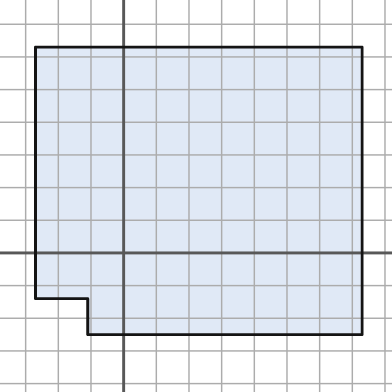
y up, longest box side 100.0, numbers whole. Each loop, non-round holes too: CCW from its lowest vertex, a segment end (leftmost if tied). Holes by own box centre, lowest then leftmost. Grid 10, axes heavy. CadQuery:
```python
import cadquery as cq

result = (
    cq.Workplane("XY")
    .moveTo(-11.0, -25.0)
    .lineTo(73.0, -25.0)
    .lineTo(73.0, 63.0)
    .lineTo(-27.0, 63.0)
    .lineTo(-27.0, -14.0)
    .lineTo(-11.0, -14.0)
    .close()
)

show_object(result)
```